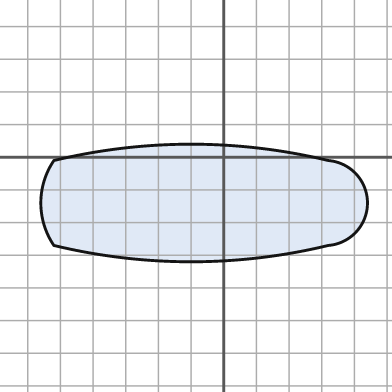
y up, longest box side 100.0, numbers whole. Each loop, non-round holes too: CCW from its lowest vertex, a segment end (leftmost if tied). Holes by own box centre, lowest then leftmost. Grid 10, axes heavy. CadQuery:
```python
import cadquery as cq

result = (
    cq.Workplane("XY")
    .moveTo(-52.0, -27.0)
    .threePointArc((-10.0, -32.0), (32.0, -27.0))
    .threePointArc((44.0, -14.0), (32.0, -1.0))
    .threePointArc((-10.0, 4.0), (-52.0, -1.0))
    .threePointArc((-56.0, -14.0), (-52.0, -27.0))
    .close()
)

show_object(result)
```